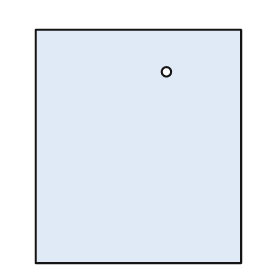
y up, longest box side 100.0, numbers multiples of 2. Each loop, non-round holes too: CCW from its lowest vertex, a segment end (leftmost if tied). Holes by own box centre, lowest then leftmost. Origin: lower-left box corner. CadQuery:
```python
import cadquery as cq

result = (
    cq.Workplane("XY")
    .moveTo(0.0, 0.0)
    .lineTo(88.0, 0.0)
    .lineTo(88.0, 100.0)
    .lineTo(0.0, 100.0)
    .close()
    .moveTo(56.0, 82.0)
    .circle(2.0)
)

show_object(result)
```